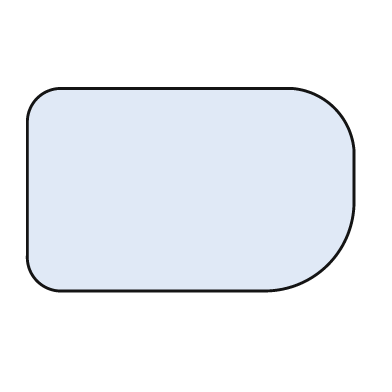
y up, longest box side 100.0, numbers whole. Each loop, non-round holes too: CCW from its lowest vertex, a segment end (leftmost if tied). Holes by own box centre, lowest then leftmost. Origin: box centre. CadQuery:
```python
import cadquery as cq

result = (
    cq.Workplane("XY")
    .moveTo(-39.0, -31.0)
    .lineTo(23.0, -31.0)
    .threePointArc((42.0, -23.0), (50.0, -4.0))
    .lineTo(50.0, 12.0)
    .threePointArc((44.0, 25.0), (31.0, 31.0))
    .lineTo(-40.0, 31.0)
    .threePointArc((-47.0, 28.0), (-50.0, 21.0))
    .lineTo(-50.0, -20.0)
    .threePointArc((-47.0, -28.0), (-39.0, -31.0))
    .close()
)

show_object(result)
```